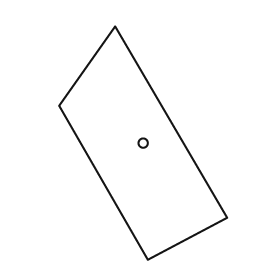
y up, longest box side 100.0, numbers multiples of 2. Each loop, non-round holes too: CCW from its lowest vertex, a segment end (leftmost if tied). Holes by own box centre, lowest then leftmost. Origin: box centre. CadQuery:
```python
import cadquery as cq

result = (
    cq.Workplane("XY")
    .moveTo(2.0, -50.0)
    .lineTo(36.0, -32.0)
    .lineTo(-12.0, 50.0)
    .lineTo(-36.0, 16.0)
    .close()
    .moveTo(0.0, 0.0)
    .circle(2.0)
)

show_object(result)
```